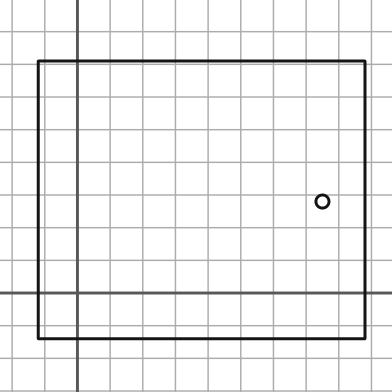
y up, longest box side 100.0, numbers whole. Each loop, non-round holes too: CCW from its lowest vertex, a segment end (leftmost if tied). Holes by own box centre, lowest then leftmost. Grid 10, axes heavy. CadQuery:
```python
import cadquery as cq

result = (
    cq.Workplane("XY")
    .moveTo(-12.0, -14.0)
    .lineTo(88.0, -14.0)
    .lineTo(88.0, 71.0)
    .lineTo(-12.0, 71.0)
    .close()
    .moveTo(75.0, 28.0)
    .circle(2.0)
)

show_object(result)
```